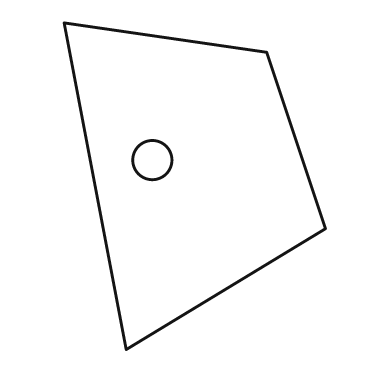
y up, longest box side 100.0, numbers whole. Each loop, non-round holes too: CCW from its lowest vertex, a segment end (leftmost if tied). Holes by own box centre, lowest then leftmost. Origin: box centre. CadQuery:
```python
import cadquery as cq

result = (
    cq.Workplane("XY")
    .moveTo(-21.0, -50.0)
    .lineTo(40.0, -13.0)
    .lineTo(22.0, 41.0)
    .lineTo(-40.0, 50.0)
    .close()
    .moveTo(-13.0, 8.0)
    .circle(6.0)
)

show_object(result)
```